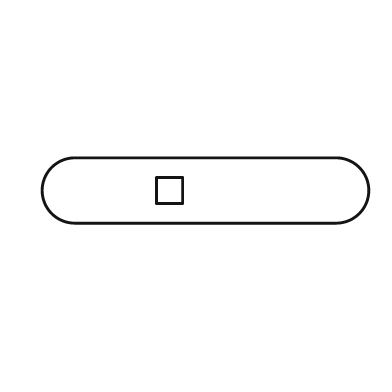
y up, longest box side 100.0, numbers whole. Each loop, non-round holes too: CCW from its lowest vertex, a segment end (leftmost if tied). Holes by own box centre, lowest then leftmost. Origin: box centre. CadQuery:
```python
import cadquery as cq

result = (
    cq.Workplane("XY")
    .moveTo(-40.0, -10.0)
    .lineTo(40.0, -10.0)
    .threePointArc((50.0, 0.0), (40.0, 10.0))
    .lineTo(-40.0, 10.0)
    .threePointArc((-50.0, 0.0), (-40.0, -10.0))
    .close()
    .moveTo(-15.0, -4.0)
    .lineTo(-7.0, -4.0)
    .lineTo(-7.0, 4.0)
    .lineTo(-15.0, 4.0)
    .close()
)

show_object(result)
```